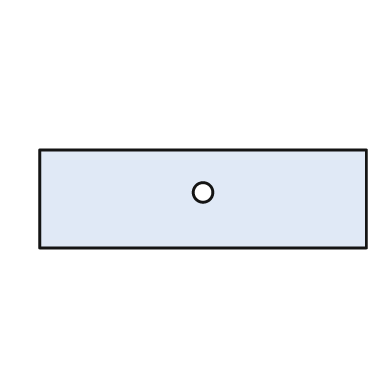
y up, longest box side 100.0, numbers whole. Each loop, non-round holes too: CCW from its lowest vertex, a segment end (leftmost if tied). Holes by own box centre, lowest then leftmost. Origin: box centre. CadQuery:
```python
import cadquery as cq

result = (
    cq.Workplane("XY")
    .moveTo(-50.0, -15.0)
    .lineTo(50.0, -15.0)
    .lineTo(50.0, 15.0)
    .lineTo(-50.0, 15.0)
    .close()
    .moveTo(0.0, 2.0)
    .circle(3.0)
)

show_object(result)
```